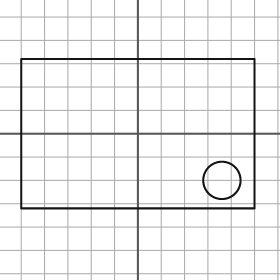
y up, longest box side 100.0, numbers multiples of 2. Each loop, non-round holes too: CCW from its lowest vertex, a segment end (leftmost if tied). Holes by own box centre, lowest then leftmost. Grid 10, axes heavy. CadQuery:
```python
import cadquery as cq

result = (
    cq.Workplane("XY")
    .moveTo(-50.0, -32.0)
    .lineTo(50.0, -32.0)
    .lineTo(50.0, 32.0)
    .lineTo(-50.0, 32.0)
    .close()
    .moveTo(36.0, -20.0)
    .circle(8.0)
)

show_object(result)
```